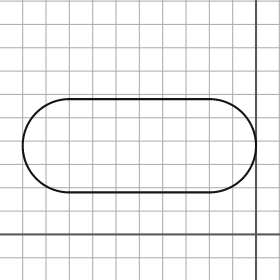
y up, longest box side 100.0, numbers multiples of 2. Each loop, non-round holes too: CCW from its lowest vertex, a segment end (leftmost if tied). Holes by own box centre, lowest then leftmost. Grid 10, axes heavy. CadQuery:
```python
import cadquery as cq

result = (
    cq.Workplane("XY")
    .moveTo(-80.0, 18.0)
    .lineTo(-20.0, 18.0)
    .threePointArc((0.0, 38.0), (-20.0, 58.0))
    .lineTo(-80.0, 58.0)
    .threePointArc((-100.0, 38.0), (-80.0, 18.0))
    .close()
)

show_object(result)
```